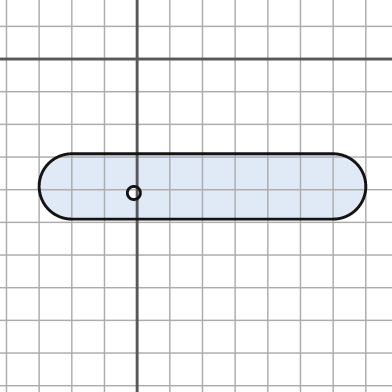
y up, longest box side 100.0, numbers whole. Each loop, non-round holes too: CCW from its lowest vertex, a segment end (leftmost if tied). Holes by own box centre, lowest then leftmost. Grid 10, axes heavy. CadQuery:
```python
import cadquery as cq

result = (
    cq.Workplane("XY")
    .moveTo(-20.0, -49.0)
    .lineTo(60.0, -49.0)
    .threePointArc((70.0, -39.0), (60.0, -29.0))
    .lineTo(-20.0, -29.0)
    .threePointArc((-30.0, -39.0), (-20.0, -49.0))
    .close()
    .moveTo(-1.0, -41.0)
    .circle(2.0)
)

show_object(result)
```